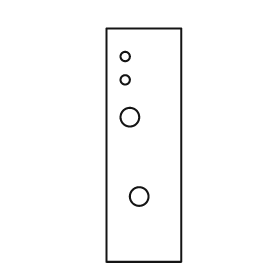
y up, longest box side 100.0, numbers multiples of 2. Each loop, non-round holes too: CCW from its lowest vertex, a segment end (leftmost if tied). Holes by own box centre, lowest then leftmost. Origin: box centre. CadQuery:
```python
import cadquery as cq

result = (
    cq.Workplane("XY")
    .moveTo(-16.0, -50.0)
    .lineTo(16.0, -50.0)
    .lineTo(16.0, 50.0)
    .lineTo(-16.0, 50.0)
    .close()
    .moveTo(-2.0, -22.0)
    .circle(4.0)
    .moveTo(-6.0, 12.0)
    .circle(4.0)
    .moveTo(-8.0, 28.0)
    .circle(2.0)
    .moveTo(-8.0, 38.0)
    .circle(2.0)
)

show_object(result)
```